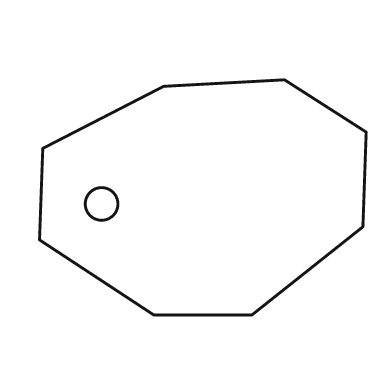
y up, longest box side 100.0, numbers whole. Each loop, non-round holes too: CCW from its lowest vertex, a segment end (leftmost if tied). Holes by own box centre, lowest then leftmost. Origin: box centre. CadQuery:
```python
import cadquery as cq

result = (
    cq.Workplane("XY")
    .moveTo(-15.0, -36.0)
    .lineTo(15.0, -36.0)
    .lineTo(49.0, -9.0)
    .lineTo(50.0, 20.0)
    .lineTo(25.0, 36.0)
    .lineTo(-12.0, 34.0)
    .lineTo(-49.0, 15.0)
    .lineTo(-50.0, -13.0)
    .close()
    .moveTo(-31.0, -2.0)
    .circle(5.0)
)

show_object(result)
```